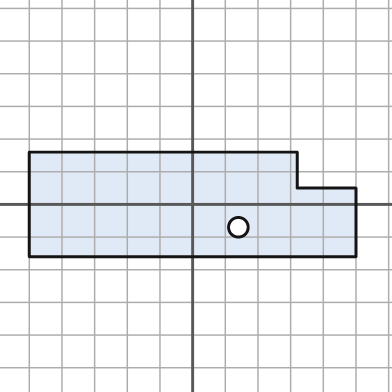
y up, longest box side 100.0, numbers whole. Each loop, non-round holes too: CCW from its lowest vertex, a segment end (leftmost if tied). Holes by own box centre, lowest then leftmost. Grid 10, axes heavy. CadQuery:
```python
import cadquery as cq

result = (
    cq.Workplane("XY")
    .moveTo(-50.0, -16.0)
    .lineTo(50.0, -16.0)
    .lineTo(50.0, 5.0)
    .lineTo(32.0, 5.0)
    .lineTo(32.0, 16.0)
    .lineTo(-50.0, 16.0)
    .close()
    .moveTo(14.0, -7.0)
    .circle(3.0)
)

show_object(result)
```